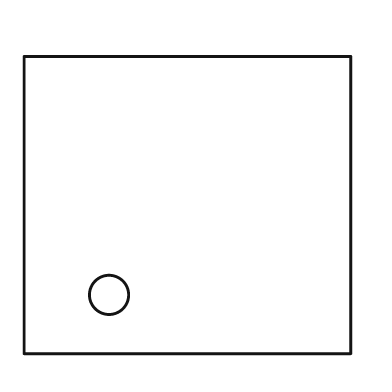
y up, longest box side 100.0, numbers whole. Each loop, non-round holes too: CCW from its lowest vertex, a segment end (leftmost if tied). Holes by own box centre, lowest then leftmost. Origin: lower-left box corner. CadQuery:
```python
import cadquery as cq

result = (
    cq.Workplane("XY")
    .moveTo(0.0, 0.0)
    .lineTo(100.0, 0.0)
    .lineTo(100.0, 91.0)
    .lineTo(0.0, 91.0)
    .close()
    .moveTo(26.0, 18.0)
    .circle(6.0)
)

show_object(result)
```